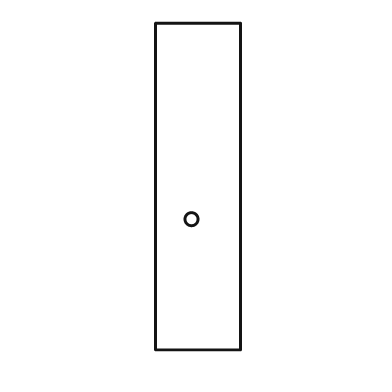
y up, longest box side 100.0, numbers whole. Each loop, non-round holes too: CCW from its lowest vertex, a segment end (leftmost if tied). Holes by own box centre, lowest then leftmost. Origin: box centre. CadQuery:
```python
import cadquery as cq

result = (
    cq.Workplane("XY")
    .moveTo(-13.0, -50.0)
    .lineTo(13.0, -50.0)
    .lineTo(13.0, 50.0)
    .lineTo(-13.0, 50.0)
    .close()
    .moveTo(-2.0, -10.0)
    .circle(2.0)
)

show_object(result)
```